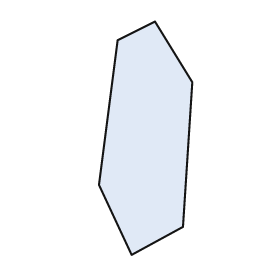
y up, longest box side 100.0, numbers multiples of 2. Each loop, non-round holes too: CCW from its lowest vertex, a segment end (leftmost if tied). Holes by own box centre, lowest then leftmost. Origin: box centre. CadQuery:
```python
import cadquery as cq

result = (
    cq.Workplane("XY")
    .moveTo(-6.0, -50.0)
    .lineTo(16.0, -38.0)
    .lineTo(20.0, 24.0)
    .lineTo(4.0, 50.0)
    .lineTo(-12.0, 42.0)
    .lineTo(-20.0, -20.0)
    .close()
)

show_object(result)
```